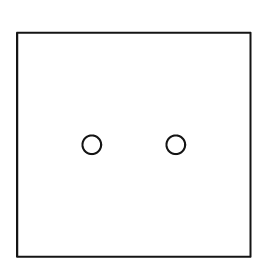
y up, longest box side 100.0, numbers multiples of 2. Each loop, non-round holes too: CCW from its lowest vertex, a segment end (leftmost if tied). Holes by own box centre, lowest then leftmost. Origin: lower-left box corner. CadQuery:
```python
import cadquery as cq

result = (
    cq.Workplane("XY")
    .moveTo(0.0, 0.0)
    .lineTo(100.0, 0.0)
    .lineTo(100.0, 96.0)
    .lineTo(0.0, 96.0)
    .close()
    .moveTo(32.0, 48.0)
    .circle(4.0)
    .moveTo(68.0, 48.0)
    .circle(4.0)
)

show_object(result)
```